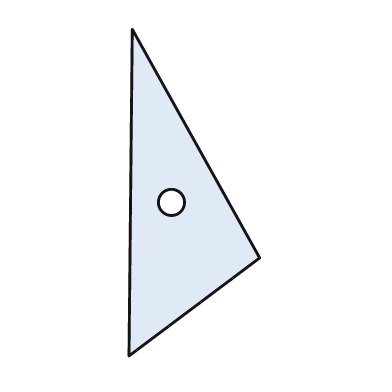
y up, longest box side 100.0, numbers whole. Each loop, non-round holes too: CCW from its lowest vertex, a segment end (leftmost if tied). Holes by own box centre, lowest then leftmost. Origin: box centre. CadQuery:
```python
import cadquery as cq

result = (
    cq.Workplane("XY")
    .moveTo(-20.0, -50.0)
    .lineTo(20.0, -20.0)
    .lineTo(-19.0, 50.0)
    .close()
    .moveTo(-7.0, -3.0)
    .circle(4.0)
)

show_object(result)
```